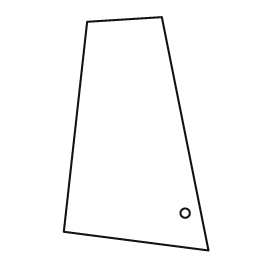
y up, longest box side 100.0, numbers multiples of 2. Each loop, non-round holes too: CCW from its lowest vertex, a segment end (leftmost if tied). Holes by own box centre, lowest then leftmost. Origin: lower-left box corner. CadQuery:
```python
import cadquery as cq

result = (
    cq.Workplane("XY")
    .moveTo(62.0, 0.0)
    .lineTo(42.0, 100.0)
    .lineTo(10.0, 98.0)
    .lineTo(0.0, 8.0)
    .close()
    .moveTo(52.0, 16.0)
    .circle(2.0)
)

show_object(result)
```